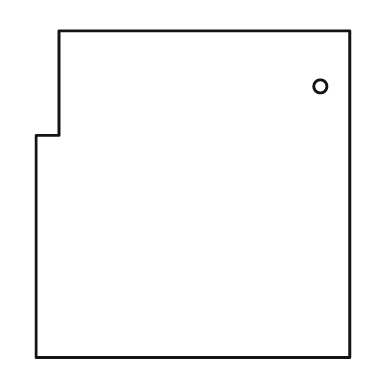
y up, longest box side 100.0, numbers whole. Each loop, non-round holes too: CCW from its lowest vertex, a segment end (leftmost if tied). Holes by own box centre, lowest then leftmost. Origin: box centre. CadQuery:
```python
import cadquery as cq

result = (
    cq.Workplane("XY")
    .moveTo(-48.0, -50.0)
    .lineTo(48.0, -50.0)
    .lineTo(48.0, 50.0)
    .lineTo(-41.0, 50.0)
    .lineTo(-41.0, 18.0)
    .lineTo(-48.0, 18.0)
    .close()
    .moveTo(39.0, 33.0)
    .circle(2.0)
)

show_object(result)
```